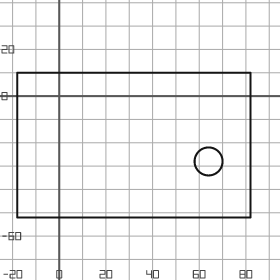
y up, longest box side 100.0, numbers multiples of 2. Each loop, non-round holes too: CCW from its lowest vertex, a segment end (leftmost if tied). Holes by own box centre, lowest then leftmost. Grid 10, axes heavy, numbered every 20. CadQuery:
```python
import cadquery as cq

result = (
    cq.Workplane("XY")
    .moveTo(-18.0, -52.0)
    .lineTo(82.0, -52.0)
    .lineTo(82.0, 10.0)
    .lineTo(-18.0, 10.0)
    .close()
    .moveTo(64.0, -28.0)
    .circle(6.0)
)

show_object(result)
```